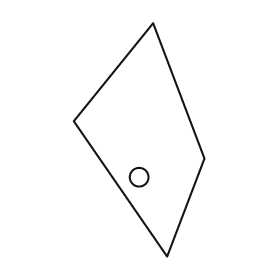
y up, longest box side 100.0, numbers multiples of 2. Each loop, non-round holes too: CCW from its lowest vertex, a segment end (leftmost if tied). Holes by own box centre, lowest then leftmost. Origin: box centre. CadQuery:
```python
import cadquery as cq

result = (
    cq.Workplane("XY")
    .moveTo(12.0, -50.0)
    .lineTo(28.0, -8.0)
    .lineTo(6.0, 50.0)
    .lineTo(-28.0, 8.0)
    .close()
    .moveTo(0.0, -16.0)
    .circle(4.0)
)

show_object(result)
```